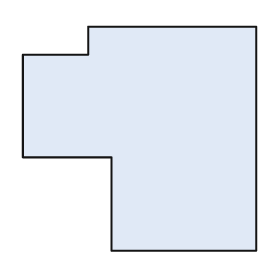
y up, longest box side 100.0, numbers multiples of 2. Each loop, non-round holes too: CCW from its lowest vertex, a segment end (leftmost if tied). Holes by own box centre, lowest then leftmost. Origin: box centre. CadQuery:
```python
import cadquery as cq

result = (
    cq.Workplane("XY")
    .moveTo(-12.0, -48.0)
    .lineTo(50.0, -48.0)
    .lineTo(50.0, 48.0)
    .lineTo(-22.0, 48.0)
    .lineTo(-22.0, 36.0)
    .lineTo(-50.0, 36.0)
    .lineTo(-50.0, -8.0)
    .lineTo(-12.0, -8.0)
    .close()
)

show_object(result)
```